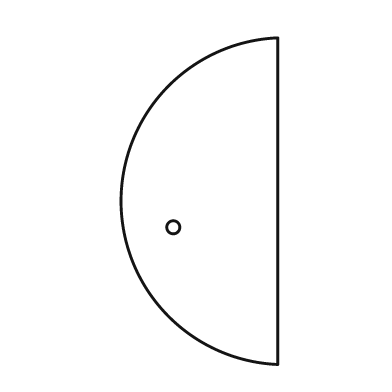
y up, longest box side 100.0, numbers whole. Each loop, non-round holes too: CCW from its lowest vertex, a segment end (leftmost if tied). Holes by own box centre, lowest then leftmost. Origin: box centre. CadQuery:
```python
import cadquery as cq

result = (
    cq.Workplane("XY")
    .moveTo(24.0, -50.0)
    .lineTo(24.0, 50.0)
    .threePointArc((-24.0, 0.0), (24.0, -50.0))
    .close()
    .moveTo(-8.0, -8.0)
    .circle(2.0)
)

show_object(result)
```